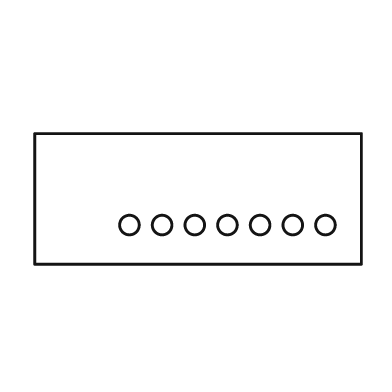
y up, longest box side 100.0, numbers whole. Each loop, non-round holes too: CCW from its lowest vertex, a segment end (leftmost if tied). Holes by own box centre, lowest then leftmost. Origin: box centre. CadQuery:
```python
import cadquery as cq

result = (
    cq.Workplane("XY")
    .moveTo(-50.0, -20.0)
    .lineTo(50.0, -20.0)
    .lineTo(50.0, 20.0)
    .lineTo(-50.0, 20.0)
    .close()
    .moveTo(-21.0, -8.0)
    .circle(3.0)
    .moveTo(-11.0, -8.0)
    .circle(3.0)
    .moveTo(-1.0, -8.0)
    .circle(3.0)
    .moveTo(9.0, -8.0)
    .circle(3.0)
    .moveTo(19.0, -8.0)
    .circle(3.0)
    .moveTo(29.0, -8.0)
    .circle(3.0)
    .moveTo(39.0, -8.0)
    .circle(3.0)
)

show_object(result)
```